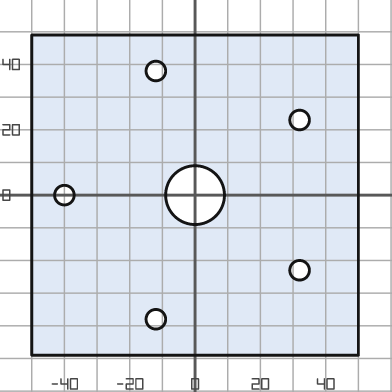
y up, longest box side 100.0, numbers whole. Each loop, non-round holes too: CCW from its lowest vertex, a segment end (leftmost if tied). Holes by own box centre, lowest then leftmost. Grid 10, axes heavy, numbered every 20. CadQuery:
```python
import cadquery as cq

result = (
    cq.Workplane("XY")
    .moveTo(-50.0, -49.0)
    .lineTo(50.0, -49.0)
    .lineTo(50.0, 49.0)
    .lineTo(-50.0, 49.0)
    .close()
    .moveTo(-12.0, -38.0)
    .circle(3.0)
    .moveTo(32.0, -23.0)
    .circle(3.0)
    .moveTo(-40.0, 0.0)
    .circle(3.0)
    .moveTo(0.0, 0.0)
    .circle(9.0)
    .moveTo(32.0, 23.0)
    .circle(3.0)
    .moveTo(-12.0, 38.0)
    .circle(3.0)
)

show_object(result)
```